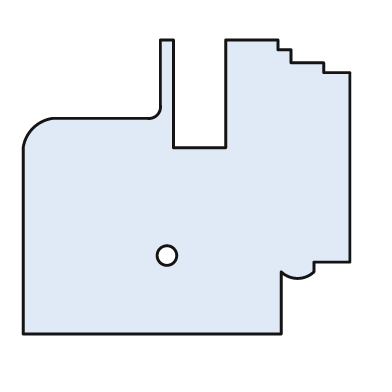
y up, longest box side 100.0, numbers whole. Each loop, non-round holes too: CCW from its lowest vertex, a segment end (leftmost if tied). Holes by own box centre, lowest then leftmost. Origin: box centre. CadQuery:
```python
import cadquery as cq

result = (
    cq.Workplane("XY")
    .moveTo(-50.0, -45.0)
    .lineTo(29.0, -45.0)
    .lineTo(29.0, -26.0)
    .threePointArc((34.0, -28.0), (39.0, -26.0))
    .lineTo(39.0, -23.0)
    .lineTo(50.0, -23.0)
    .lineTo(50.0, 35.0)
    .lineTo(42.0, 35.0)
    .lineTo(42.0, 38.0)
    .lineTo(32.0, 38.0)
    .lineTo(32.0, 42.0)
    .lineTo(28.0, 42.0)
    .lineTo(28.0, 45.0)
    .lineTo(12.0, 45.0)
    .lineTo(12.0, 12.0)
    .lineTo(-4.0, 12.0)
    .lineTo(-4.0, 45.0)
    .lineTo(-8.0, 45.0)
    .lineTo(-8.0, 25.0)
    .threePointArc((-9.0, 22.0), (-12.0, 21.0))
    .lineTo(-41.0, 21.0)
    .threePointArc((-47.0, 18.0), (-50.0, 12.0))
    .close()
    .moveTo(-6.0, -21.0)
    .circle(3.0)
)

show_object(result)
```